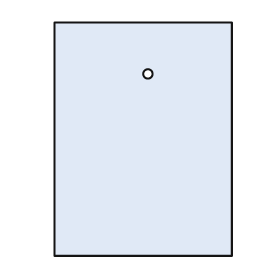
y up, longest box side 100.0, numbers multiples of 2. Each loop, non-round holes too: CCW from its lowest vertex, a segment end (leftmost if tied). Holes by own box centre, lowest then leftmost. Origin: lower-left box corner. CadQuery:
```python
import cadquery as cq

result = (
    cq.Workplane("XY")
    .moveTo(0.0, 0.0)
    .lineTo(76.0, 0.0)
    .lineTo(76.0, 100.0)
    .lineTo(0.0, 100.0)
    .close()
    .moveTo(40.0, 78.0)
    .circle(2.0)
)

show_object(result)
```